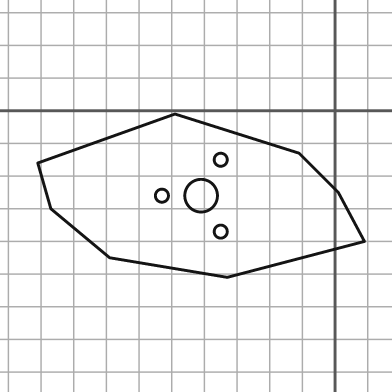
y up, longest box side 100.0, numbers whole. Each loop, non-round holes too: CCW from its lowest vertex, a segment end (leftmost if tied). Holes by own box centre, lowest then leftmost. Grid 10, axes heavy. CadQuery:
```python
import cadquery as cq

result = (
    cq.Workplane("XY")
    .moveTo(-33.0, -51.0)
    .lineTo(9.0, -40.0)
    .lineTo(1.0, -25.0)
    .lineTo(-11.0, -13.0)
    .lineTo(-49.0, -1.0)
    .lineTo(-91.0, -16.0)
    .lineTo(-87.0, -30.0)
    .lineTo(-69.0, -45.0)
    .close()
    .moveTo(-35.0, -37.0)
    .circle(2.0)
    .moveTo(-53.0, -26.0)
    .circle(2.0)
    .moveTo(-41.0, -26.0)
    .circle(5.0)
    .moveTo(-35.0, -15.0)
    .circle(2.0)
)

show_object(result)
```